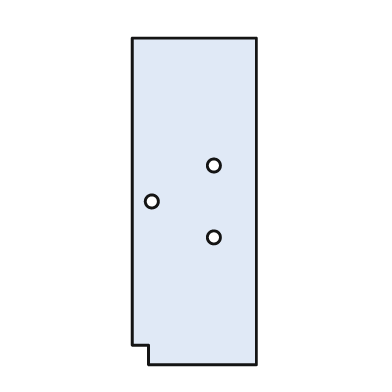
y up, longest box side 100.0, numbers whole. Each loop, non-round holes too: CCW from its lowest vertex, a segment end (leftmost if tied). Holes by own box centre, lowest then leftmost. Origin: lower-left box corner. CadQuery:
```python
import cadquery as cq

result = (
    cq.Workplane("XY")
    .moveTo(5.0, 0.0)
    .lineTo(38.0, 0.0)
    .lineTo(38.0, 100.0)
    .lineTo(0.0, 100.0)
    .lineTo(0.0, 6.0)
    .lineTo(5.0, 6.0)
    .close()
    .moveTo(25.0, 39.0)
    .circle(2.0)
    .moveTo(6.0, 50.0)
    .circle(2.0)
    .moveTo(25.0, 61.0)
    .circle(2.0)
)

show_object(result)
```